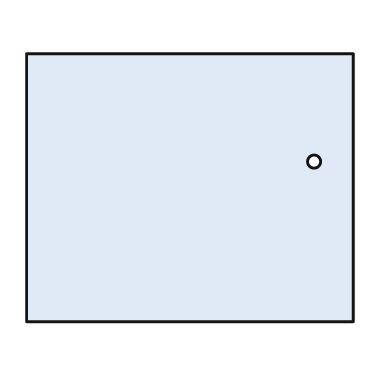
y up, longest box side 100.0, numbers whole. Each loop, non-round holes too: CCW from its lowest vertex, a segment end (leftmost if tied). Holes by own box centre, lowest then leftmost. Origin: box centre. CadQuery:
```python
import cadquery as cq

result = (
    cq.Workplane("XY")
    .moveTo(-50.0, -41.0)
    .lineTo(50.0, -41.0)
    .lineTo(50.0, 41.0)
    .lineTo(-50.0, 41.0)
    .close()
    .moveTo(38.0, 8.0)
    .circle(2.0)
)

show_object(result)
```